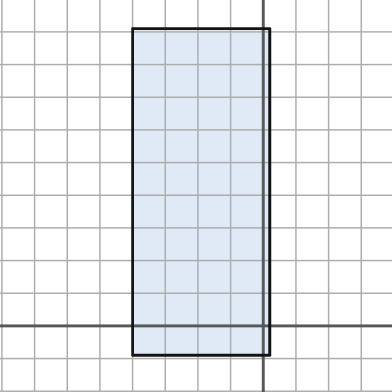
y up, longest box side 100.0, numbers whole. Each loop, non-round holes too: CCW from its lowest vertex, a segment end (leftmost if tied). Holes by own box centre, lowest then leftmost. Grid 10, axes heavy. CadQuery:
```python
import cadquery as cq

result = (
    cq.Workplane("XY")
    .moveTo(-40.0, -9.0)
    .lineTo(2.0, -9.0)
    .lineTo(2.0, 91.0)
    .lineTo(-40.0, 91.0)
    .close()
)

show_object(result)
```